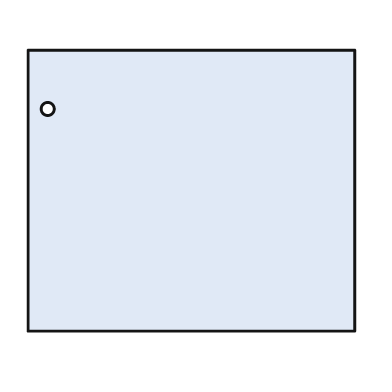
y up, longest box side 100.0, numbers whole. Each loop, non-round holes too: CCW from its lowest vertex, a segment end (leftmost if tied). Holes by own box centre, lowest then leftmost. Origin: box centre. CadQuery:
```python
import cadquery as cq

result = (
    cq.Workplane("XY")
    .moveTo(-50.0, -43.0)
    .lineTo(50.0, -43.0)
    .lineTo(50.0, 43.0)
    .lineTo(-50.0, 43.0)
    .close()
    .moveTo(-44.0, 25.0)
    .circle(2.0)
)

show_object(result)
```